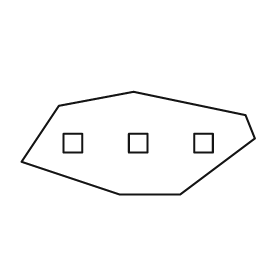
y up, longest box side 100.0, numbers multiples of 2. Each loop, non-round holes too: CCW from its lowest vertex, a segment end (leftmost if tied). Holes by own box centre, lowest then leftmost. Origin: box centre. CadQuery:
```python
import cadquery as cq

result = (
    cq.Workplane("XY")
    .moveTo(-8.0, -22.0)
    .lineTo(18.0, -22.0)
    .lineTo(50.0, 2.0)
    .lineTo(46.0, 12.0)
    .lineTo(-2.0, 22.0)
    .lineTo(-34.0, 16.0)
    .lineTo(-50.0, -8.0)
    .close()
    .moveTo(-32.0, -4.0)
    .lineTo(-24.0, -4.0)
    .lineTo(-24.0, 4.0)
    .lineTo(-32.0, 4.0)
    .close()
    .moveTo(-4.0, -4.0)
    .lineTo(4.0, -4.0)
    .lineTo(4.0, 4.0)
    .lineTo(-4.0, 4.0)
    .close()
    .moveTo(24.0, -4.0)
    .lineTo(32.0, -4.0)
    .lineTo(32.0, 4.0)
    .lineTo(24.0, 4.0)
    .close()
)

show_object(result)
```